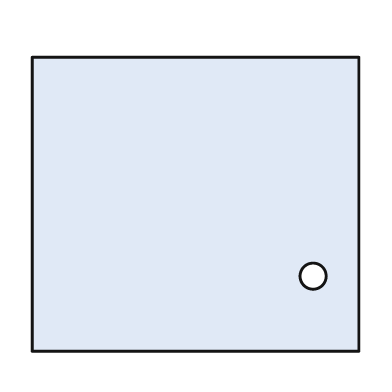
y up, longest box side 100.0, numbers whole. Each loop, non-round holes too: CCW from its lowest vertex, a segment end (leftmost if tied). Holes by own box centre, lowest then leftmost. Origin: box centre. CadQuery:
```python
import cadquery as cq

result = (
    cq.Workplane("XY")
    .moveTo(-50.0, -45.0)
    .lineTo(50.0, -45.0)
    .lineTo(50.0, 45.0)
    .lineTo(-50.0, 45.0)
    .close()
    .moveTo(36.0, -22.0)
    .circle(4.0)
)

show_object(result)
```